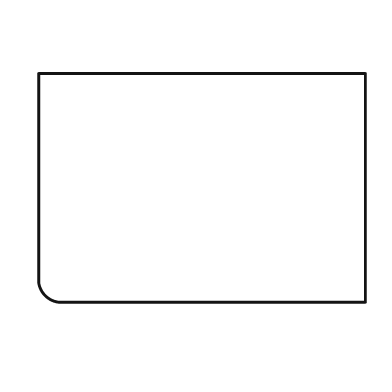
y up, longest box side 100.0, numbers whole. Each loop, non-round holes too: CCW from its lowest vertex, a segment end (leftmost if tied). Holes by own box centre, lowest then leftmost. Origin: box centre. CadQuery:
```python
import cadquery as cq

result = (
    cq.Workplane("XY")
    .moveTo(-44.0, -35.0)
    .lineTo(50.0, -35.0)
    .lineTo(50.0, 35.0)
    .lineTo(-50.0, 35.0)
    .lineTo(-50.0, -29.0)
    .threePointArc((-48.0, -33.0), (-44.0, -35.0))
    .close()
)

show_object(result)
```